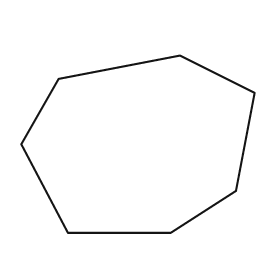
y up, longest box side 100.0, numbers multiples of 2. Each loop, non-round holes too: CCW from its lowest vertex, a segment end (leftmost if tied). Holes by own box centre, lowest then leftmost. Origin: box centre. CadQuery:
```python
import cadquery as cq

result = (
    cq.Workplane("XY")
    .moveTo(-30.0, -38.0)
    .lineTo(14.0, -38.0)
    .lineTo(42.0, -20.0)
    .lineTo(50.0, 22.0)
    .lineTo(18.0, 38.0)
    .lineTo(-34.0, 28.0)
    .lineTo(-50.0, 0.0)
    .close()
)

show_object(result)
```